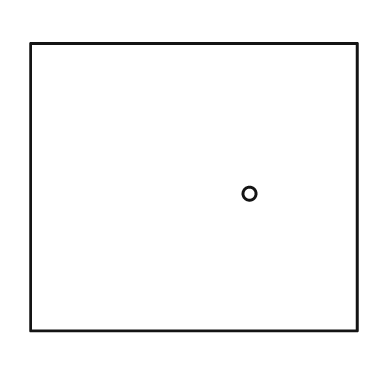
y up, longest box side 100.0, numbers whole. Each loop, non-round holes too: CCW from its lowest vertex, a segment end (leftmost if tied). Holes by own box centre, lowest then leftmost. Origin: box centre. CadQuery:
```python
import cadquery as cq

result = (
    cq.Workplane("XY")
    .moveTo(-50.0, -44.0)
    .lineTo(50.0, -44.0)
    .lineTo(50.0, 44.0)
    .lineTo(-50.0, 44.0)
    .close()
    .moveTo(17.0, -2.0)
    .circle(2.0)
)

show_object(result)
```